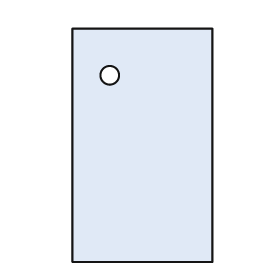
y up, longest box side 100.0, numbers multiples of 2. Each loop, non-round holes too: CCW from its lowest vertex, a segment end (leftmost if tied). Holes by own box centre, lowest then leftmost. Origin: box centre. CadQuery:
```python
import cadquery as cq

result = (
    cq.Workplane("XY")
    .moveTo(-30.0, -50.0)
    .lineTo(30.0, -50.0)
    .lineTo(30.0, 50.0)
    .lineTo(-30.0, 50.0)
    .close()
    .moveTo(-14.0, 30.0)
    .circle(4.0)
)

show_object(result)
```